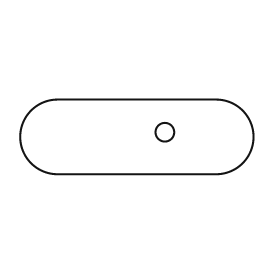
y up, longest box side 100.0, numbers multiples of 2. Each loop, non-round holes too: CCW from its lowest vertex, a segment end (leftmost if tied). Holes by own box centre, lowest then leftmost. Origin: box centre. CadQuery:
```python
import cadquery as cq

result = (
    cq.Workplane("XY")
    .moveTo(-34.0, -16.0)
    .lineTo(34.0, -16.0)
    .threePointArc((50.0, 0.0), (34.0, 16.0))
    .lineTo(-34.0, 16.0)
    .threePointArc((-50.0, 0.0), (-34.0, -16.0))
    .close()
    .moveTo(12.0, 2.0)
    .circle(4.0)
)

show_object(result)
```